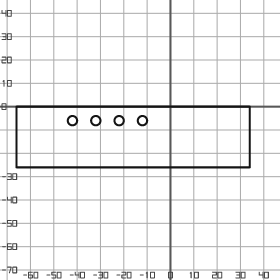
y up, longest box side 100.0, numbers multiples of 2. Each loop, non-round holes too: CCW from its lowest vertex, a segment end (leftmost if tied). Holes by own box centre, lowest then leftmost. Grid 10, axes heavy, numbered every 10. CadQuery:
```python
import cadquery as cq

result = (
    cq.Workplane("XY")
    .moveTo(-66.0, -26.0)
    .lineTo(34.0, -26.0)
    .lineTo(34.0, 0.0)
    .lineTo(-66.0, 0.0)
    .close()
    .moveTo(-42.0, -6.0)
    .circle(2.0)
    .moveTo(-32.0, -6.0)
    .circle(2.0)
    .moveTo(-22.0, -6.0)
    .circle(2.0)
    .moveTo(-12.0, -6.0)
    .circle(2.0)
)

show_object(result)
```